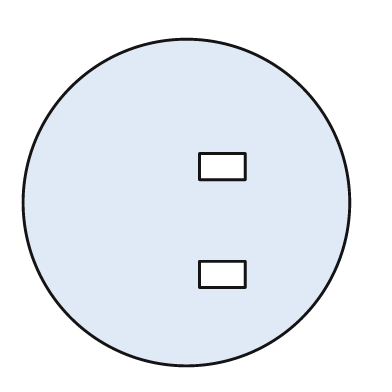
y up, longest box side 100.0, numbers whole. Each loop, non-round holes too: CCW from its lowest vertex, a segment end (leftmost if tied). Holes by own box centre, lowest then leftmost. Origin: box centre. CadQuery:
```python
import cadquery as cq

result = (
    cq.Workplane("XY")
    .moveTo(0.0, 0.0)
    .circle(50.0)
    .moveTo(4.0, -26.0)
    .lineTo(18.0, -26.0)
    .lineTo(18.0, -18.0)
    .lineTo(4.0, -18.0)
    .close()
    .moveTo(4.0, 7.0)
    .lineTo(18.0, 7.0)
    .lineTo(18.0, 15.0)
    .lineTo(4.0, 15.0)
    .close()
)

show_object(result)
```